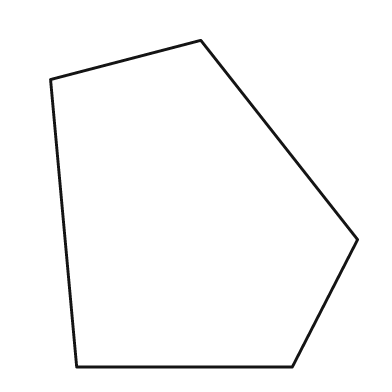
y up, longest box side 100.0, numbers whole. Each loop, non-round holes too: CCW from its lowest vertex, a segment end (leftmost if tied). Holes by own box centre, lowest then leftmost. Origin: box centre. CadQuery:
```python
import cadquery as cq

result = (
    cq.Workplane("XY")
    .moveTo(-39.0, -50.0)
    .lineTo(27.0, -50.0)
    .lineTo(47.0, -11.0)
    .lineTo(-1.0, 50.0)
    .lineTo(-47.0, 38.0)
    .close()
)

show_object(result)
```